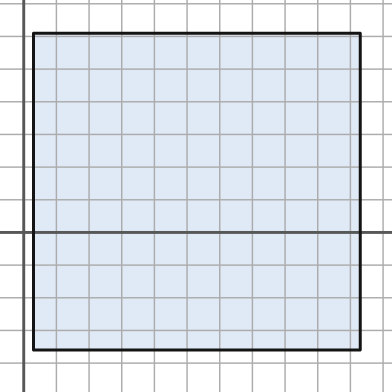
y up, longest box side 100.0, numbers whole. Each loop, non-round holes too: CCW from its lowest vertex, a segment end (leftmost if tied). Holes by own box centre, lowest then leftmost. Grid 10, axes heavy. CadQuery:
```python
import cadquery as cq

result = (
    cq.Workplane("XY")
    .moveTo(3.0, -36.0)
    .lineTo(103.0, -36.0)
    .lineTo(103.0, 61.0)
    .lineTo(3.0, 61.0)
    .close()
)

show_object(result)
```